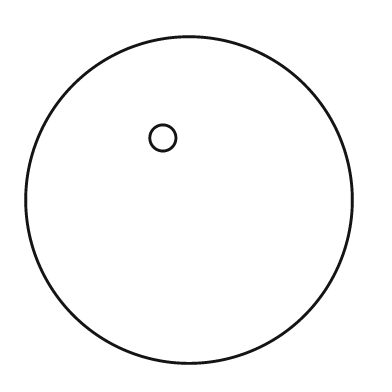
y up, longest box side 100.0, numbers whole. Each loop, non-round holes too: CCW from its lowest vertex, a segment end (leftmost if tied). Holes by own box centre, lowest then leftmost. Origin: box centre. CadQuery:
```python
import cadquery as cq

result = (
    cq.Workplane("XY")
    .moveTo(0.0, 0.0)
    .circle(50.0)
    .moveTo(-8.0, 19.0)
    .circle(4.0)
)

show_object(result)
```